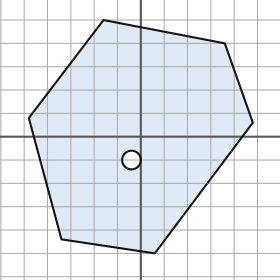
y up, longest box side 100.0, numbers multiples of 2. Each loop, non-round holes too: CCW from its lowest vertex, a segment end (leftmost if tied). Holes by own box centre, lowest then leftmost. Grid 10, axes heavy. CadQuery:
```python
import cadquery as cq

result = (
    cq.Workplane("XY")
    .moveTo(6.0, -50.0)
    .lineTo(48.0, 6.0)
    .lineTo(36.0, 40.0)
    .lineTo(-16.0, 50.0)
    .lineTo(-48.0, 8.0)
    .lineTo(-34.0, -44.0)
    .close()
    .moveTo(-4.0, -10.0)
    .circle(4.0)
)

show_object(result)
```